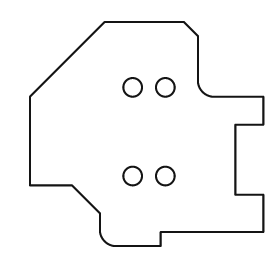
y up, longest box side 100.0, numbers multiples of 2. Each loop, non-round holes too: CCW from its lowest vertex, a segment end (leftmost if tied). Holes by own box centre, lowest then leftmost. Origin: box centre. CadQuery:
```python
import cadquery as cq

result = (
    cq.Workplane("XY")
    .moveTo(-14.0, -48.0)
    .lineTo(6.0, -48.0)
    .lineTo(6.0, -42.0)
    .lineTo(50.0, -42.0)
    .lineTo(50.0, -26.0)
    .lineTo(38.0, -26.0)
    .lineTo(38.0, 4.0)
    .lineTo(50.0, 4.0)
    .lineTo(50.0, 16.0)
    .lineTo(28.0, 16.0)
    .threePointArc((24.0, 18.0), (22.0, 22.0))
    .lineTo(22.0, 42.0)
    .lineTo(16.0, 48.0)
    .lineTo(-18.0, 48.0)
    .lineTo(-50.0, 16.0)
    .lineTo(-50.0, -22.0)
    .lineTo(-32.0, -22.0)
    .lineTo(-20.0, -34.0)
    .lineTo(-20.0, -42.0)
    .threePointArc((-18.0, -46.0), (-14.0, -48.0))
    .close()
    .moveTo(-6.0, -18.0)
    .circle(4.0)
    .moveTo(8.0, -18.0)
    .circle(4.0)
    .moveTo(-6.0, 20.0)
    .circle(4.0)
    .moveTo(8.0, 20.0)
    .circle(4.0)
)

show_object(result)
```